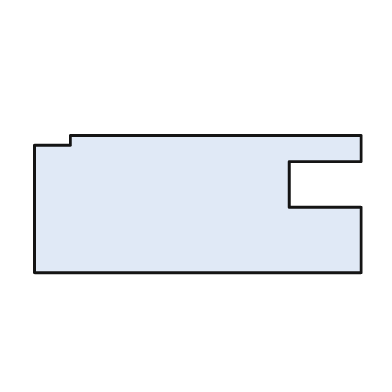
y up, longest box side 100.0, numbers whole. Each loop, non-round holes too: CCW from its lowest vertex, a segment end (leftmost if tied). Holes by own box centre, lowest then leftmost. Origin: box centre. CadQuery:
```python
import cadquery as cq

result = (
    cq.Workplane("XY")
    .moveTo(-50.0, -21.0)
    .lineTo(50.0, -21.0)
    .lineTo(50.0, -1.0)
    .lineTo(28.0, -1.0)
    .lineTo(28.0, 13.0)
    .lineTo(50.0, 13.0)
    .lineTo(50.0, 21.0)
    .lineTo(-39.0, 21.0)
    .lineTo(-39.0, 18.0)
    .lineTo(-50.0, 18.0)
    .close()
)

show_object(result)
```